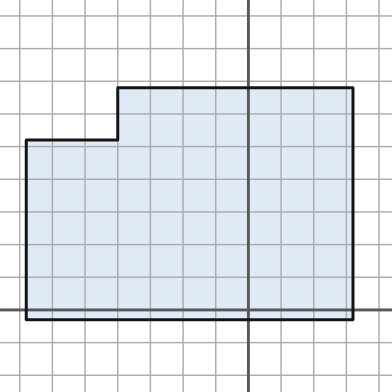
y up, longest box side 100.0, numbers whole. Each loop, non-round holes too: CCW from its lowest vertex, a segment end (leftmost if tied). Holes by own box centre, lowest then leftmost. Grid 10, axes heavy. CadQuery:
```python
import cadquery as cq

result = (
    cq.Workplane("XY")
    .moveTo(-68.0, -3.0)
    .lineTo(32.0, -3.0)
    .lineTo(32.0, 68.0)
    .lineTo(-40.0, 68.0)
    .lineTo(-40.0, 52.0)
    .lineTo(-68.0, 52.0)
    .close()
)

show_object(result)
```